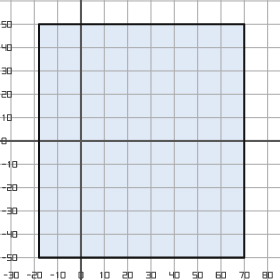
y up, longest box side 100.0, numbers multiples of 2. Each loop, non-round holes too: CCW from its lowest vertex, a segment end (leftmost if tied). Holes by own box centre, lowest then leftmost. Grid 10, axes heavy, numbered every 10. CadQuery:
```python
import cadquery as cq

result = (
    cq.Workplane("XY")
    .moveTo(-18.0, -50.0)
    .lineTo(70.0, -50.0)
    .lineTo(70.0, 50.0)
    .lineTo(-18.0, 50.0)
    .close()
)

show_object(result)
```